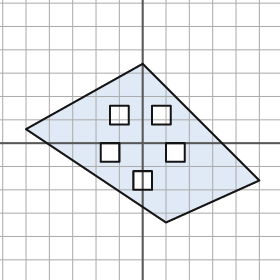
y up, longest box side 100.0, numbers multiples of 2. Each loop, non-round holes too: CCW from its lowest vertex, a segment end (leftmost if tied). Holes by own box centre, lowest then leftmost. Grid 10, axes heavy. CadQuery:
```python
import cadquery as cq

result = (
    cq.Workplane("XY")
    .moveTo(10.0, -34.0)
    .lineTo(50.0, -16.0)
    .lineTo(0.0, 34.0)
    .lineTo(-50.0, 6.0)
    .close()
    .moveTo(-4.0, -20.0)
    .lineTo(4.0, -20.0)
    .lineTo(4.0, -12.0)
    .lineTo(-4.0, -12.0)
    .close()
    .moveTo(-18.0, -8.0)
    .lineTo(-10.0, -8.0)
    .lineTo(-10.0, 0.0)
    .lineTo(-18.0, 0.0)
    .close()
    .moveTo(10.0, -8.0)
    .lineTo(18.0, -8.0)
    .lineTo(18.0, 0.0)
    .lineTo(10.0, 0.0)
    .close()
    .moveTo(-14.0, 8.0)
    .lineTo(-6.0, 8.0)
    .lineTo(-6.0, 16.0)
    .lineTo(-14.0, 16.0)
    .close()
    .moveTo(4.0, 8.0)
    .lineTo(12.0, 8.0)
    .lineTo(12.0, 16.0)
    .lineTo(4.0, 16.0)
    .close()
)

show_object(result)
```